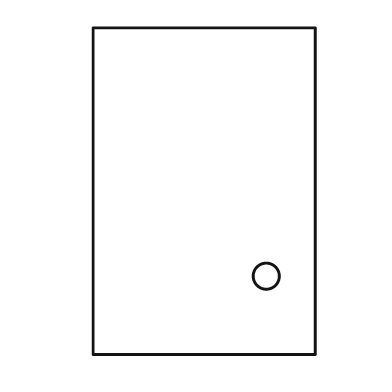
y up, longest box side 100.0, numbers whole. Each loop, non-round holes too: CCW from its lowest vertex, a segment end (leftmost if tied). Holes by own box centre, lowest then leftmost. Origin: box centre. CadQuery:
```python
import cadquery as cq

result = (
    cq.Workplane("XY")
    .moveTo(-34.0, -50.0)
    .lineTo(34.0, -50.0)
    .lineTo(34.0, 50.0)
    .lineTo(-34.0, 50.0)
    .close()
    .moveTo(19.0, -26.0)
    .circle(4.0)
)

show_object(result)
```